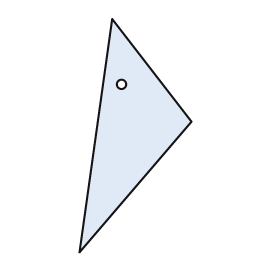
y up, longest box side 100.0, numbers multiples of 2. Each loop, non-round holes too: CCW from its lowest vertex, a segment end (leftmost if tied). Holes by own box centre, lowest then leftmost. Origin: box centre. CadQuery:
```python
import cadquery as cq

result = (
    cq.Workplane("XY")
    .moveTo(-24.0, -50.0)
    .lineTo(24.0, 6.0)
    .lineTo(-10.0, 50.0)
    .close()
    .moveTo(-6.0, 22.0)
    .circle(2.0)
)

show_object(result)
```